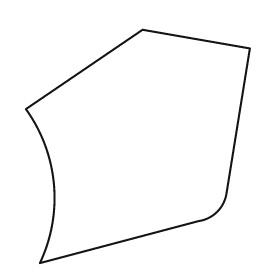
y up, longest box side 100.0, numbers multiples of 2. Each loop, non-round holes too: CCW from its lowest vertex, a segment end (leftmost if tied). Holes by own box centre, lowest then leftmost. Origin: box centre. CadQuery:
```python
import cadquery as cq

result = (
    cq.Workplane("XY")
    .moveTo(-42.0, -50.0)
    .lineTo(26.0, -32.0)
    .threePointArc((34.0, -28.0), (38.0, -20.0))
    .lineTo(48.0, 42.0)
    .lineTo(2.0, 50.0)
    .lineTo(-48.0, 16.0)
    .threePointArc((-36.0, -16.0), (-42.0, -50.0))
    .close()
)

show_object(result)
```